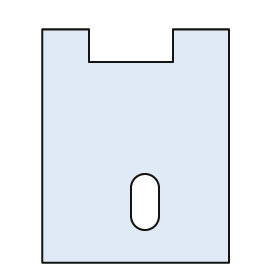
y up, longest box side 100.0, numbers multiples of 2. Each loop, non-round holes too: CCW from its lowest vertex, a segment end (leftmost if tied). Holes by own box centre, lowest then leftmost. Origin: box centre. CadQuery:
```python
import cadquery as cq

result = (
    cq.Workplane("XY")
    .moveTo(-40.0, -50.0)
    .lineTo(40.0, -50.0)
    .lineTo(40.0, 50.0)
    .lineTo(16.0, 50.0)
    .lineTo(16.0, 36.0)
    .lineTo(-20.0, 36.0)
    .lineTo(-20.0, 50.0)
    .lineTo(-40.0, 50.0)
    .close()
    .moveTo(-2.0, -30.0)
    .threePointArc((4.0, -36.0), (10.0, -30.0))
    .lineTo(10.0, -18.0)
    .threePointArc((4.0, -12.0), (-2.0, -18.0))
    .close()
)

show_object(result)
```